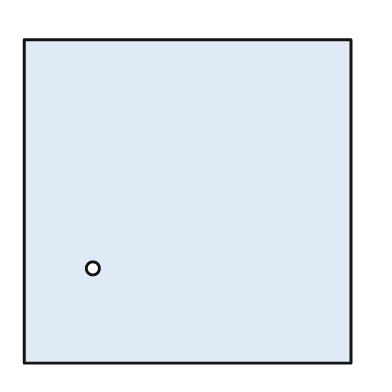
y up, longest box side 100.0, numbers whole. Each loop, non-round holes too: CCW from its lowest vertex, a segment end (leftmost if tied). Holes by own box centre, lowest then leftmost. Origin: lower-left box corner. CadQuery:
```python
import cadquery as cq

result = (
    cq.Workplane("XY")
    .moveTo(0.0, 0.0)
    .lineTo(100.0, 0.0)
    .lineTo(100.0, 99.0)
    .lineTo(0.0, 99.0)
    .close()
    .moveTo(21.0, 29.0)
    .circle(2.0)
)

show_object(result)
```